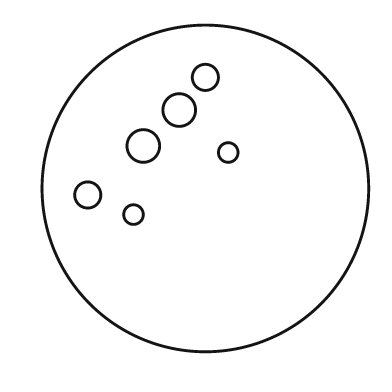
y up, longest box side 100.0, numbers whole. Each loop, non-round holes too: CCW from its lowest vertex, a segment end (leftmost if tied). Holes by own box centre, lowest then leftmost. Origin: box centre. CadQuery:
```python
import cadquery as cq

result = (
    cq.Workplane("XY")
    .moveTo(0.0, 0.0)
    .circle(50.0)
    .moveTo(-22.0, -8.0)
    .circle(3.0)
    .moveTo(-36.0, -2.0)
    .circle(4.0)
    .moveTo(7.0, 11.0)
    .circle(3.0)
    .moveTo(-19.0, 13.0)
    .circle(5.0)
    .moveTo(-8.0, 24.0)
    .circle(5.0)
    .moveTo(0.0, 34.0)
    .circle(4.0)
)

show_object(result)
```